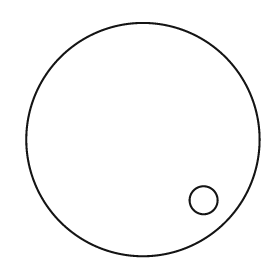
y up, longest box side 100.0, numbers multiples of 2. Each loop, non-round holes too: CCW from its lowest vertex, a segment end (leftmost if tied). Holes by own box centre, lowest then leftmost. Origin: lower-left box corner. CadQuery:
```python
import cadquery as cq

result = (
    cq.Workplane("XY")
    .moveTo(50.0, 50.0)
    .circle(50.0)
    .moveTo(76.0, 24.0)
    .circle(6.0)
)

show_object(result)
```